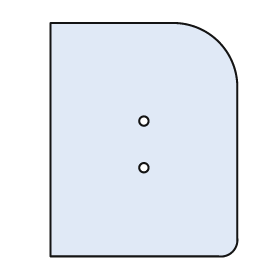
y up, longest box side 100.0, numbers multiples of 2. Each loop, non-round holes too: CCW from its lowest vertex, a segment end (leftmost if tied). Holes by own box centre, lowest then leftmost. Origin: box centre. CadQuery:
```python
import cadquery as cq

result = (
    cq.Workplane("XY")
    .moveTo(-40.0, -50.0)
    .lineTo(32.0, -50.0)
    .threePointArc((38.0, -48.0), (40.0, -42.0))
    .lineTo(40.0, 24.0)
    .threePointArc((32.0, 42.0), (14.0, 50.0))
    .lineTo(-40.0, 50.0)
    .close()
    .moveTo(0.0, -12.0)
    .circle(2.0)
    .moveTo(0.0, 8.0)
    .circle(2.0)
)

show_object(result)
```